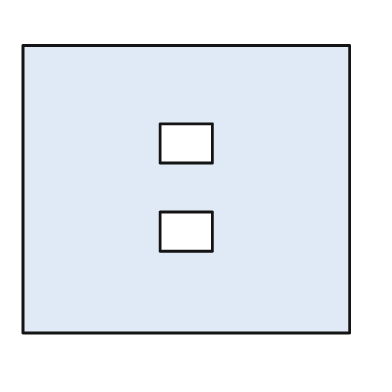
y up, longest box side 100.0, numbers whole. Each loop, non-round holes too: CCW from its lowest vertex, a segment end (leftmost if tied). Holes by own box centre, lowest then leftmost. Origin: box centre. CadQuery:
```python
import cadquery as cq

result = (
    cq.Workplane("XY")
    .moveTo(-50.0, -44.0)
    .lineTo(50.0, -44.0)
    .lineTo(50.0, 44.0)
    .lineTo(-50.0, 44.0)
    .close()
    .moveTo(-8.0, -19.0)
    .lineTo(8.0, -19.0)
    .lineTo(8.0, -7.0)
    .lineTo(-8.0, -7.0)
    .close()
    .moveTo(-8.0, 8.0)
    .lineTo(8.0, 8.0)
    .lineTo(8.0, 20.0)
    .lineTo(-8.0, 20.0)
    .close()
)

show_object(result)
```